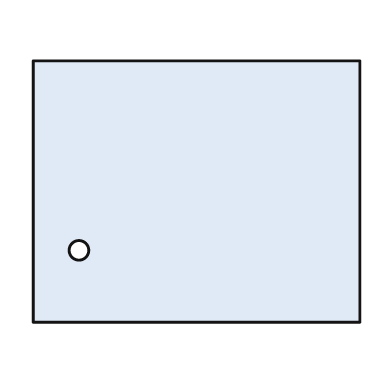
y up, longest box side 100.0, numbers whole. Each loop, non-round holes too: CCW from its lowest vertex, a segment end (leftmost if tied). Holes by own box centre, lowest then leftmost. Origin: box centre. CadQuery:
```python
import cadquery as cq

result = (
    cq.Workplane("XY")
    .moveTo(-50.0, -40.0)
    .lineTo(50.0, -40.0)
    .lineTo(50.0, 40.0)
    .lineTo(-50.0, 40.0)
    .close()
    .moveTo(-36.0, -18.0)
    .circle(3.0)
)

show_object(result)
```